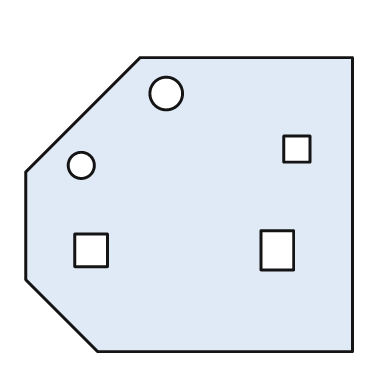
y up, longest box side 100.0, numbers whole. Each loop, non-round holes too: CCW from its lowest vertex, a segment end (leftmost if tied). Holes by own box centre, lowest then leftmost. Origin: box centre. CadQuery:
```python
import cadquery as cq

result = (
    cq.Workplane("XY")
    .moveTo(-28.0, -45.0)
    .lineTo(50.0, -45.0)
    .lineTo(50.0, 45.0)
    .lineTo(-15.0, 45.0)
    .lineTo(-50.0, 10.0)
    .lineTo(-50.0, -23.0)
    .close()
    .moveTo(-35.0, -19.0)
    .lineTo(-25.0, -19.0)
    .lineTo(-25.0, -9.0)
    .lineTo(-35.0, -9.0)
    .close()
    .moveTo(22.0, -20.0)
    .lineTo(32.0, -20.0)
    .lineTo(32.0, -8.0)
    .lineTo(22.0, -8.0)
    .close()
    .moveTo(-33.0, 12.0)
    .circle(4.0)
    .moveTo(29.0, 13.0)
    .lineTo(37.0, 13.0)
    .lineTo(37.0, 21.0)
    .lineTo(29.0, 21.0)
    .close()
    .moveTo(-7.0, 34.0)
    .circle(5.0)
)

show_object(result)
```